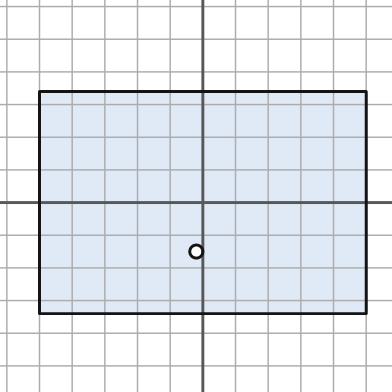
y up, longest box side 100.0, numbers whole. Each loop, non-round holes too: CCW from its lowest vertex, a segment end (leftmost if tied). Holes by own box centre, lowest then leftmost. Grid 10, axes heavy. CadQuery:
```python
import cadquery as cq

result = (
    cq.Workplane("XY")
    .moveTo(-50.0, -34.0)
    .lineTo(50.0, -34.0)
    .lineTo(50.0, 34.0)
    .lineTo(-50.0, 34.0)
    .close()
    .moveTo(-2.0, -15.0)
    .circle(2.0)
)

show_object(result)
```